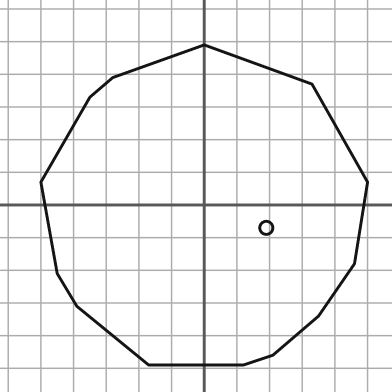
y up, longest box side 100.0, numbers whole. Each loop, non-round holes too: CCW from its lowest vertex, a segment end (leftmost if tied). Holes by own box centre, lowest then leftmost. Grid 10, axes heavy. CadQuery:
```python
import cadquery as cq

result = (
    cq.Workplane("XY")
    .moveTo(-17.0, -49.0)
    .lineTo(12.0, -49.0)
    .lineTo(21.0, -46.0)
    .lineTo(35.0, -34.0)
    .lineTo(46.0, -18.0)
    .lineTo(50.0, 7.0)
    .lineTo(33.0, 37.0)
    .lineTo(0.0, 49.0)
    .lineTo(-28.0, 39.0)
    .lineTo(-35.0, 33.0)
    .lineTo(-50.0, 7.0)
    .lineTo(-45.0, -21.0)
    .lineTo(-39.0, -31.0)
    .close()
    .moveTo(19.0, -7.0)
    .circle(2.0)
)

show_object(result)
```